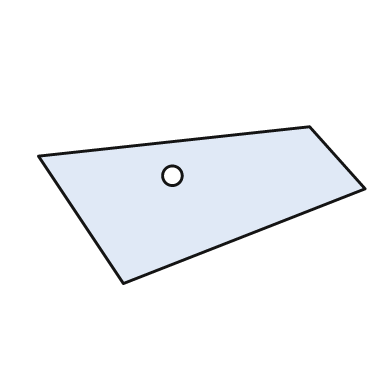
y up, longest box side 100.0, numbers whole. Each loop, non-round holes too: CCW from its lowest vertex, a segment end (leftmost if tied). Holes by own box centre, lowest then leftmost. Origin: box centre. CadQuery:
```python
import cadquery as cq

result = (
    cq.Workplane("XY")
    .moveTo(-24.0, -24.0)
    .lineTo(50.0, 5.0)
    .lineTo(33.0, 24.0)
    .lineTo(-50.0, 15.0)
    .close()
    .moveTo(-9.0, 9.0)
    .circle(3.0)
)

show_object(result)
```